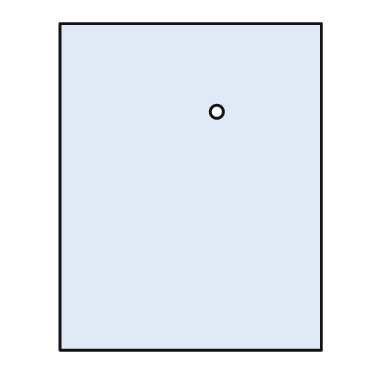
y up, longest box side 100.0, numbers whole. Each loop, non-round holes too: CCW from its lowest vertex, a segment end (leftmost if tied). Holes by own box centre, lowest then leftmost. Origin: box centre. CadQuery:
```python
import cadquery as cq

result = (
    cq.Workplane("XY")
    .moveTo(-40.0, -50.0)
    .lineTo(40.0, -50.0)
    .lineTo(40.0, 50.0)
    .lineTo(-40.0, 50.0)
    .close()
    .moveTo(8.0, 23.0)
    .circle(2.0)
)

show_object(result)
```